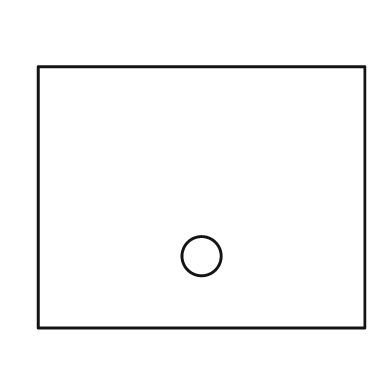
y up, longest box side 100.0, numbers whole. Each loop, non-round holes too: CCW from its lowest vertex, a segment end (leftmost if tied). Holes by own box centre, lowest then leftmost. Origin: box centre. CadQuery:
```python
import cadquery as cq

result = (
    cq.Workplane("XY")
    .moveTo(-50.0, -40.0)
    .lineTo(50.0, -40.0)
    .lineTo(50.0, 40.0)
    .lineTo(-50.0, 40.0)
    .close()
    .moveTo(0.0, -18.0)
    .circle(6.0)
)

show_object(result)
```